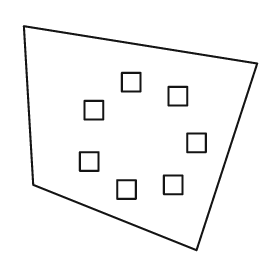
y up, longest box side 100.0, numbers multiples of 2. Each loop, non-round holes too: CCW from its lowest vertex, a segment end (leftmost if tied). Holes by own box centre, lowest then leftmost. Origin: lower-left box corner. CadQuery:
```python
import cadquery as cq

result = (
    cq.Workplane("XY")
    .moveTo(74.0, 0.0)
    .lineTo(100.0, 80.0)
    .lineTo(0.0, 96.0)
    .lineTo(4.0, 28.0)
    .close()
    .moveTo(40.0, 22.0)
    .lineTo(48.0, 22.0)
    .lineTo(48.0, 30.0)
    .lineTo(40.0, 30.0)
    .close()
    .moveTo(60.0, 24.0)
    .lineTo(68.0, 24.0)
    .lineTo(68.0, 32.0)
    .lineTo(60.0, 32.0)
    .close()
    .moveTo(24.0, 34.0)
    .lineTo(32.0, 34.0)
    .lineTo(32.0, 42.0)
    .lineTo(24.0, 42.0)
    .close()
    .moveTo(70.0, 42.0)
    .lineTo(78.0, 42.0)
    .lineTo(78.0, 50.0)
    .lineTo(70.0, 50.0)
    .close()
    .moveTo(26.0, 56.0)
    .lineTo(34.0, 56.0)
    .lineTo(34.0, 64.0)
    .lineTo(26.0, 64.0)
    .close()
    .moveTo(62.0, 62.0)
    .lineTo(70.0, 62.0)
    .lineTo(70.0, 70.0)
    .lineTo(62.0, 70.0)
    .close()
    .moveTo(42.0, 68.0)
    .lineTo(50.0, 68.0)
    .lineTo(50.0, 76.0)
    .lineTo(42.0, 76.0)
    .close()
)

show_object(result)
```